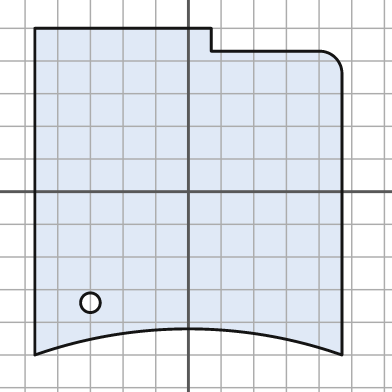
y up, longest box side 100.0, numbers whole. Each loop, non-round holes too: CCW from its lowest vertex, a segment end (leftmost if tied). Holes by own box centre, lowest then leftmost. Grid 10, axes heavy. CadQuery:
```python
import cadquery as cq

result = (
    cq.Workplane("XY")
    .moveTo(-47.0, -50.0)
    .threePointArc((0.0, -42.0), (47.0, -50.0))
    .lineTo(47.0, 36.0)
    .threePointArc((45.0, 41.0), (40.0, 43.0))
    .lineTo(7.0, 43.0)
    .lineTo(7.0, 50.0)
    .lineTo(-47.0, 50.0)
    .close()
    .moveTo(-30.0, -34.0)
    .circle(3.0)
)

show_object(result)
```